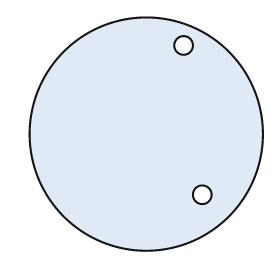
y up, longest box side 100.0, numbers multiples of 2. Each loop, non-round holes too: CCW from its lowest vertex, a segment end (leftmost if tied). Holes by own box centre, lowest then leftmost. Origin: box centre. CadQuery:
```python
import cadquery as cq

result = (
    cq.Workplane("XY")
    .moveTo(0.0, 0.0)
    .circle(50.0)
    .moveTo(24.0, -26.0)
    .circle(4.0)
    .moveTo(16.0, 38.0)
    .circle(4.0)
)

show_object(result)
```